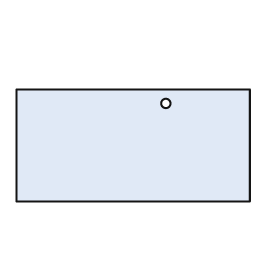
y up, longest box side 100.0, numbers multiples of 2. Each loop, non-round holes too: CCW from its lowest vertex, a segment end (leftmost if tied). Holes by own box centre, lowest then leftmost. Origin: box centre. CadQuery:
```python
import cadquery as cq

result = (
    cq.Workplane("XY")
    .moveTo(-50.0, -24.0)
    .lineTo(50.0, -24.0)
    .lineTo(50.0, 24.0)
    .lineTo(-50.0, 24.0)
    .close()
    .moveTo(14.0, 18.0)
    .circle(2.0)
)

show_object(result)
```